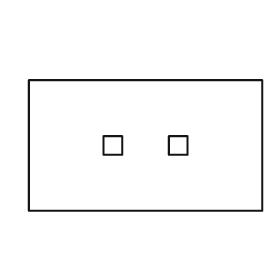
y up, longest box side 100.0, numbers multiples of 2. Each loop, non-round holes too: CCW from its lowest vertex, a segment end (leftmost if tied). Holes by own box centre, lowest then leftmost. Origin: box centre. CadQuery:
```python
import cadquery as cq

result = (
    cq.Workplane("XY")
    .moveTo(-50.0, -28.0)
    .lineTo(50.0, -28.0)
    .lineTo(50.0, 28.0)
    .lineTo(-50.0, 28.0)
    .close()
    .moveTo(-18.0, -4.0)
    .lineTo(-10.0, -4.0)
    .lineTo(-10.0, 4.0)
    .lineTo(-18.0, 4.0)
    .close()
    .moveTo(10.0, -4.0)
    .lineTo(18.0, -4.0)
    .lineTo(18.0, 4.0)
    .lineTo(10.0, 4.0)
    .close()
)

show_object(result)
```